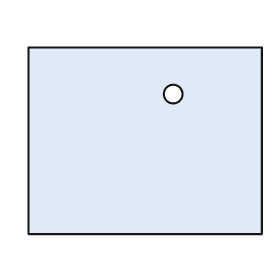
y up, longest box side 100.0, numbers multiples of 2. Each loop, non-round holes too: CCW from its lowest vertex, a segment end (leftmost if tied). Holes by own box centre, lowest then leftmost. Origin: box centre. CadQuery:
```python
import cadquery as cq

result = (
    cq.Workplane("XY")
    .moveTo(-50.0, -40.0)
    .lineTo(50.0, -40.0)
    .lineTo(50.0, 40.0)
    .lineTo(-50.0, 40.0)
    .close()
    .moveTo(12.0, 20.0)
    .circle(4.0)
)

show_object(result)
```